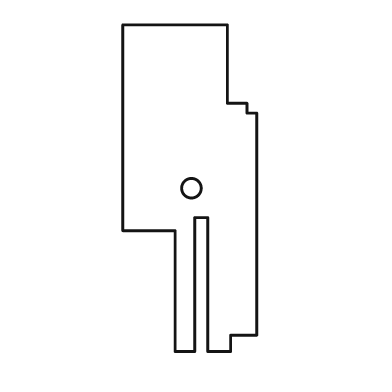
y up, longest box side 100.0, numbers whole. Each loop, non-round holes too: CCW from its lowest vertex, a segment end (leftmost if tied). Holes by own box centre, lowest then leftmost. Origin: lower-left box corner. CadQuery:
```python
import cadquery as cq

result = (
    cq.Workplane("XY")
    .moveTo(16.0, 0.0)
    .lineTo(22.0, 0.0)
    .lineTo(22.0, 41.0)
    .lineTo(26.0, 41.0)
    .lineTo(26.0, 0.0)
    .lineTo(33.0, 0.0)
    .lineTo(33.0, 5.0)
    .lineTo(41.0, 5.0)
    .lineTo(41.0, 73.0)
    .lineTo(38.0, 73.0)
    .lineTo(38.0, 76.0)
    .lineTo(32.0, 76.0)
    .lineTo(32.0, 100.0)
    .lineTo(0.0, 100.0)
    .lineTo(0.0, 37.0)
    .lineTo(16.0, 37.0)
    .close()
    .moveTo(21.0, 50.0)
    .circle(3.0)
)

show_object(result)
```